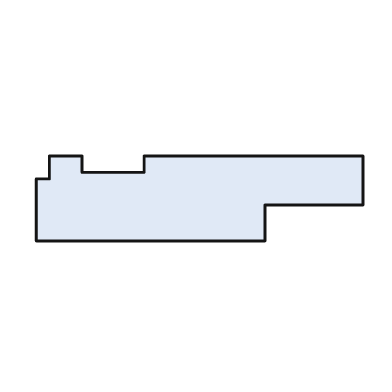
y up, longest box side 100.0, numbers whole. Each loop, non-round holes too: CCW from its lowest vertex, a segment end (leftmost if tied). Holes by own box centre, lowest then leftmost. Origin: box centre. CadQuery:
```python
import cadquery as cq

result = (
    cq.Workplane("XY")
    .moveTo(-50.0, -13.0)
    .lineTo(20.0, -13.0)
    .lineTo(20.0, -2.0)
    .lineTo(50.0, -2.0)
    .lineTo(50.0, 13.0)
    .lineTo(-17.0, 13.0)
    .lineTo(-17.0, 8.0)
    .lineTo(-36.0, 8.0)
    .lineTo(-36.0, 13.0)
    .lineTo(-46.0, 13.0)
    .lineTo(-46.0, 6.0)
    .lineTo(-50.0, 6.0)
    .close()
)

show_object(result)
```